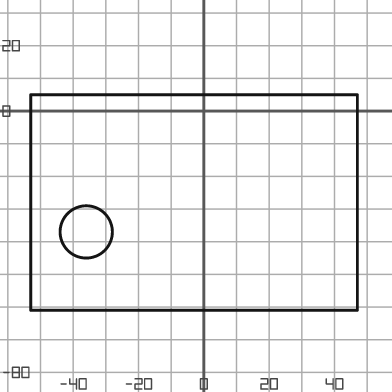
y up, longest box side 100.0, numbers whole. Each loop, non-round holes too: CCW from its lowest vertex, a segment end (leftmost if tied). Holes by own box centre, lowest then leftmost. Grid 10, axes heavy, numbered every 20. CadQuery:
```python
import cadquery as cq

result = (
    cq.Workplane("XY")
    .moveTo(-53.0, -61.0)
    .lineTo(47.0, -61.0)
    .lineTo(47.0, 5.0)
    .lineTo(-53.0, 5.0)
    .close()
    .moveTo(-36.0, -37.0)
    .circle(8.0)
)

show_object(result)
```